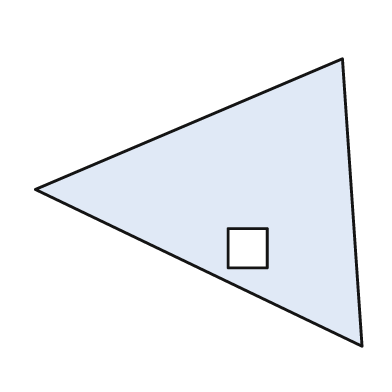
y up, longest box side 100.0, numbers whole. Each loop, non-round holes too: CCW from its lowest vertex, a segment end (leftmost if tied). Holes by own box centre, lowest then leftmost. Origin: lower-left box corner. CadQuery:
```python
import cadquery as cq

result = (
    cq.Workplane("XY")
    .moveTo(100.0, 0.0)
    .lineTo(94.0, 88.0)
    .lineTo(0.0, 48.0)
    .close()
    .moveTo(59.0, 24.0)
    .lineTo(71.0, 24.0)
    .lineTo(71.0, 36.0)
    .lineTo(59.0, 36.0)
    .close()
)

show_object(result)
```